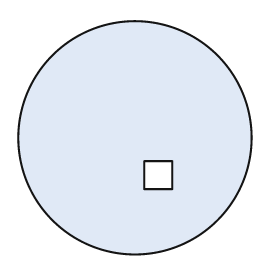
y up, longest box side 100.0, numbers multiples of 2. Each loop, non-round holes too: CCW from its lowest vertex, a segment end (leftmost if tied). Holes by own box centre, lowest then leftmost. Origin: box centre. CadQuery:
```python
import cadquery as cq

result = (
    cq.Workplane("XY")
    .moveTo(0.0, 0.0)
    .circle(50.0)
    .moveTo(4.0, -22.0)
    .lineTo(16.0, -22.0)
    .lineTo(16.0, -10.0)
    .lineTo(4.0, -10.0)
    .close()
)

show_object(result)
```